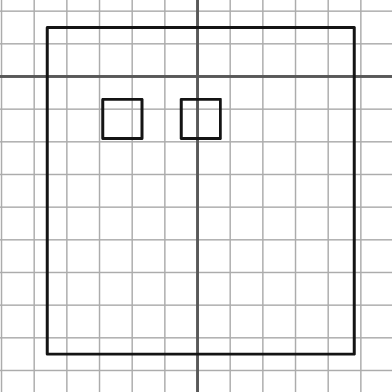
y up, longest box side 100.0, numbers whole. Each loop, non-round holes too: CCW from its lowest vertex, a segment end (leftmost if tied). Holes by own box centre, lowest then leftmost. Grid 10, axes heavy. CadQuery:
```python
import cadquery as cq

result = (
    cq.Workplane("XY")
    .moveTo(-46.0, -85.0)
    .lineTo(48.0, -85.0)
    .lineTo(48.0, 15.0)
    .lineTo(-46.0, 15.0)
    .close()
    .moveTo(-29.0, -19.0)
    .lineTo(-17.0, -19.0)
    .lineTo(-17.0, -7.0)
    .lineTo(-29.0, -7.0)
    .close()
    .moveTo(-5.0, -19.0)
    .lineTo(7.0, -19.0)
    .lineTo(7.0, -7.0)
    .lineTo(-5.0, -7.0)
    .close()
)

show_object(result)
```